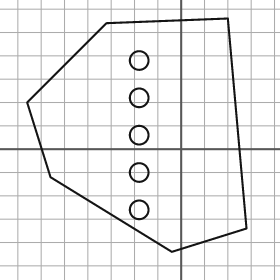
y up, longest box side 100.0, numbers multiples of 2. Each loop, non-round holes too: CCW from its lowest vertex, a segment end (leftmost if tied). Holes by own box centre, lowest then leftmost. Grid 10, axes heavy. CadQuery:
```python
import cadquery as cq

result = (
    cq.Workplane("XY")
    .moveTo(-4.0, -44.0)
    .lineTo(28.0, -34.0)
    .lineTo(20.0, 56.0)
    .lineTo(-32.0, 54.0)
    .lineTo(-66.0, 20.0)
    .lineTo(-56.0, -12.0)
    .close()
    .moveTo(-18.0, -26.0)
    .circle(4.0)
    .moveTo(-18.0, -10.0)
    .circle(4.0)
    .moveTo(-18.0, 6.0)
    .circle(4.0)
    .moveTo(-18.0, 22.0)
    .circle(4.0)
    .moveTo(-18.0, 38.0)
    .circle(4.0)
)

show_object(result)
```